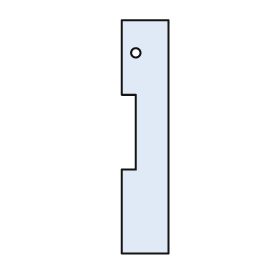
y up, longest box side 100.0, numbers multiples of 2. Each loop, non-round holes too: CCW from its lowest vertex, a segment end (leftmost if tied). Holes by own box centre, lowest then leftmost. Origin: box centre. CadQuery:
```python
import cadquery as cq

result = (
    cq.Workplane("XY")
    .moveTo(-10.0, -50.0)
    .lineTo(10.0, -50.0)
    .lineTo(10.0, 50.0)
    .lineTo(-10.0, 50.0)
    .lineTo(-10.0, 18.0)
    .lineTo(-4.0, 18.0)
    .lineTo(-4.0, -14.0)
    .lineTo(-10.0, -14.0)
    .close()
    .moveTo(-4.0, 36.0)
    .circle(2.0)
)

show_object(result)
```